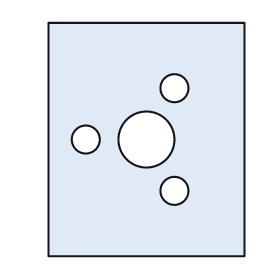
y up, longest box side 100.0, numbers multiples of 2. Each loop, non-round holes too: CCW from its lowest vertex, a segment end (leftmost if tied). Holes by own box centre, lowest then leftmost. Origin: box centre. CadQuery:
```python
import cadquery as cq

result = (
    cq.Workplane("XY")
    .moveTo(-42.0, -50.0)
    .lineTo(42.0, -50.0)
    .lineTo(42.0, 50.0)
    .lineTo(-42.0, 50.0)
    .close()
    .moveTo(12.0, -22.0)
    .circle(6.0)
    .moveTo(-26.0, 0.0)
    .circle(6.0)
    .moveTo(0.0, 0.0)
    .circle(12.0)
    .moveTo(12.0, 22.0)
    .circle(6.0)
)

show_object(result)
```